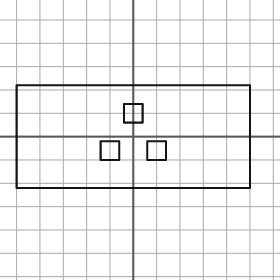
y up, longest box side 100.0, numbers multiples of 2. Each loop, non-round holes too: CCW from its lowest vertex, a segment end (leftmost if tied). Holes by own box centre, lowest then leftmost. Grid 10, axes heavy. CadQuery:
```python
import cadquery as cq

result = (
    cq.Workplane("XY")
    .moveTo(-50.0, -22.0)
    .lineTo(50.0, -22.0)
    .lineTo(50.0, 22.0)
    .lineTo(-50.0, 22.0)
    .close()
    .moveTo(-14.0, -10.0)
    .lineTo(-6.0, -10.0)
    .lineTo(-6.0, -2.0)
    .lineTo(-14.0, -2.0)
    .close()
    .moveTo(6.0, -10.0)
    .lineTo(14.0, -10.0)
    .lineTo(14.0, -2.0)
    .lineTo(6.0, -2.0)
    .close()
    .moveTo(-4.0, 6.0)
    .lineTo(4.0, 6.0)
    .lineTo(4.0, 14.0)
    .lineTo(-4.0, 14.0)
    .close()
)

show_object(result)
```